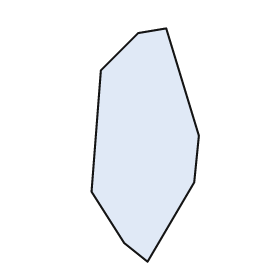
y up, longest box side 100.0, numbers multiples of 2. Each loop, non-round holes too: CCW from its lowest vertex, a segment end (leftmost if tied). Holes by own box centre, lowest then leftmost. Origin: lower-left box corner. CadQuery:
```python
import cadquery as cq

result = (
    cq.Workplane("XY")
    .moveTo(24.0, 0.0)
    .lineTo(44.0, 34.0)
    .lineTo(46.0, 54.0)
    .lineTo(32.0, 100.0)
    .lineTo(20.0, 98.0)
    .lineTo(4.0, 82.0)
    .lineTo(0.0, 30.0)
    .lineTo(14.0, 8.0)
    .close()
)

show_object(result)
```